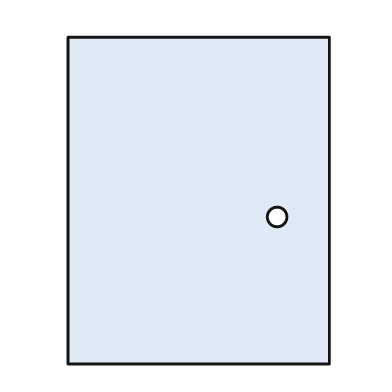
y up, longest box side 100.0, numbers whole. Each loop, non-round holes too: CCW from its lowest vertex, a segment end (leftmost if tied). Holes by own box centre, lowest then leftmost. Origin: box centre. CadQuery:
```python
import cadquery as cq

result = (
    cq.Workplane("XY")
    .moveTo(-40.0, -50.0)
    .lineTo(40.0, -50.0)
    .lineTo(40.0, 50.0)
    .lineTo(-40.0, 50.0)
    .close()
    .moveTo(24.0, -5.0)
    .circle(3.0)
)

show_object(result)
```